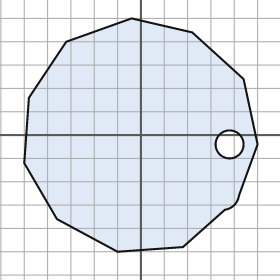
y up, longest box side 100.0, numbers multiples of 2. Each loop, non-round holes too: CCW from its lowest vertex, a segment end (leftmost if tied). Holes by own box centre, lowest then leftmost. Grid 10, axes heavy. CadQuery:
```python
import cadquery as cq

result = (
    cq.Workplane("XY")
    .moveTo(-10.0, -50.0)
    .lineTo(18.0, -48.0)
    .lineTo(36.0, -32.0)
    .threePointArc((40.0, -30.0), (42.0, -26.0))
    .lineTo(50.0, -4.0)
    .lineTo(44.0, 24.0)
    .lineTo(22.0, 44.0)
    .lineTo(-4.0, 50.0)
    .lineTo(-32.0, 40.0)
    .lineTo(-48.0, 16.0)
    .lineTo(-50.0, -12.0)
    .lineTo(-36.0, -36.0)
    .close()
    .moveTo(38.0, -4.0)
    .circle(6.0)
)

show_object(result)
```